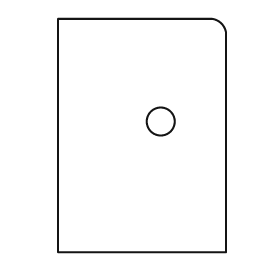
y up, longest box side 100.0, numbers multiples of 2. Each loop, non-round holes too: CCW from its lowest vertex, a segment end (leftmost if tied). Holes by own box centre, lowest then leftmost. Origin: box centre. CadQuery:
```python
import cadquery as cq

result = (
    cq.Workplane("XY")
    .moveTo(-36.0, -50.0)
    .lineTo(36.0, -50.0)
    .lineTo(36.0, 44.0)
    .threePointArc((34.0, 48.0), (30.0, 50.0))
    .lineTo(-36.0, 50.0)
    .close()
    .moveTo(8.0, 6.0)
    .circle(6.0)
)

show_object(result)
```